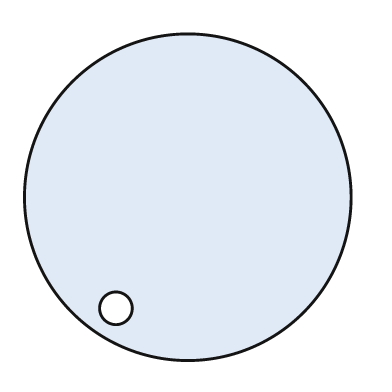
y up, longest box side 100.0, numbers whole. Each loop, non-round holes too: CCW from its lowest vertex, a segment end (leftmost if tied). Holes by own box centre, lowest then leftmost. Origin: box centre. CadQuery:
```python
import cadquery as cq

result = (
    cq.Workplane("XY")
    .moveTo(0.0, 0.0)
    .circle(50.0)
    .moveTo(-22.0, -34.0)
    .circle(5.0)
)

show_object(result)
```